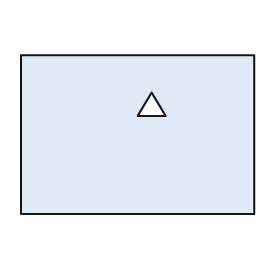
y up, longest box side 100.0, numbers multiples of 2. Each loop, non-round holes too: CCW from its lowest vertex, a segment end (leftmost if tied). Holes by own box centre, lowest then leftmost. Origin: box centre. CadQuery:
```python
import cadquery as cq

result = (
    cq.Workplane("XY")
    .moveTo(-50.0, -34.0)
    .lineTo(50.0, -34.0)
    .lineTo(50.0, 34.0)
    .lineTo(-50.0, 34.0)
    .close()
    .moveTo(0.0, 8.0)
    .lineTo(12.0, 8.0)
    .lineTo(6.0, 18.0)
    .close()
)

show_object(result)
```